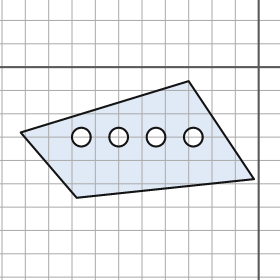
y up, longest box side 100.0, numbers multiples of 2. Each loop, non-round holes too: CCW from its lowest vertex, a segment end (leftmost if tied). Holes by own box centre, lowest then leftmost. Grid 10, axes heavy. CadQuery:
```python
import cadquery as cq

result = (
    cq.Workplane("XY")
    .moveTo(-78.0, -56.0)
    .lineTo(-2.0, -48.0)
    .lineTo(-30.0, -6.0)
    .lineTo(-102.0, -28.0)
    .close()
    .moveTo(-76.0, -30.0)
    .circle(4.0)
    .moveTo(-60.0, -30.0)
    .circle(4.0)
    .moveTo(-44.0, -30.0)
    .circle(4.0)
    .moveTo(-28.0, -30.0)
    .circle(4.0)
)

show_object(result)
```